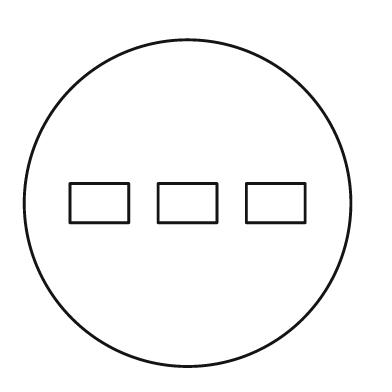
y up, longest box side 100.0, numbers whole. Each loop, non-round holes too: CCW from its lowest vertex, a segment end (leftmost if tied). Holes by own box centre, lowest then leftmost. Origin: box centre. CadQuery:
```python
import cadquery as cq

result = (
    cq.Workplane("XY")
    .moveTo(0.0, 0.0)
    .circle(50.0)
    .moveTo(-36.0, -6.0)
    .lineTo(-18.0, -6.0)
    .lineTo(-18.0, 6.0)
    .lineTo(-36.0, 6.0)
    .close()
    .moveTo(-9.0, -6.0)
    .lineTo(9.0, -6.0)
    .lineTo(9.0, 6.0)
    .lineTo(-9.0, 6.0)
    .close()
    .moveTo(18.0, -6.0)
    .lineTo(36.0, -6.0)
    .lineTo(36.0, 6.0)
    .lineTo(18.0, 6.0)
    .close()
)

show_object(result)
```